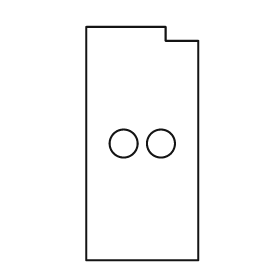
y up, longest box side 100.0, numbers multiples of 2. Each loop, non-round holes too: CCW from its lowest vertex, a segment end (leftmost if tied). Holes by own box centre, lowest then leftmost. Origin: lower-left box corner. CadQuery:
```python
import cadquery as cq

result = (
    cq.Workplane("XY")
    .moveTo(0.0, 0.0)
    .lineTo(48.0, 0.0)
    .lineTo(48.0, 94.0)
    .lineTo(34.0, 94.0)
    .lineTo(34.0, 100.0)
    .lineTo(0.0, 100.0)
    .close()
    .moveTo(16.0, 50.0)
    .circle(6.0)
    .moveTo(32.0, 50.0)
    .circle(6.0)
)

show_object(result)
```